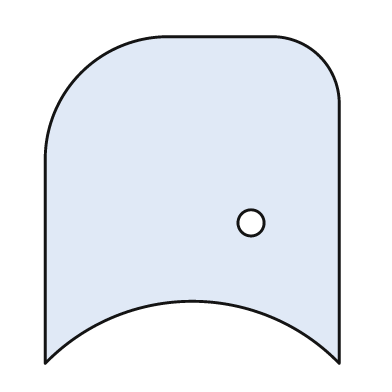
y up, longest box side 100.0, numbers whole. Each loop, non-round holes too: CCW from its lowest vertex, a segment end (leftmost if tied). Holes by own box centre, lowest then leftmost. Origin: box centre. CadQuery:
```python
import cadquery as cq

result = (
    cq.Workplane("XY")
    .moveTo(-45.0, -50.0)
    .threePointArc((0.0, -31.0), (45.0, -50.0))
    .lineTo(45.0, 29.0)
    .threePointArc((39.0, 44.0), (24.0, 50.0))
    .lineTo(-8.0, 50.0)
    .threePointArc((-34.0, 39.0), (-45.0, 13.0))
    .close()
    .moveTo(18.0, -7.0)
    .circle(4.0)
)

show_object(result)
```